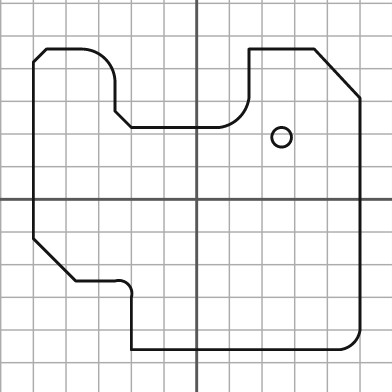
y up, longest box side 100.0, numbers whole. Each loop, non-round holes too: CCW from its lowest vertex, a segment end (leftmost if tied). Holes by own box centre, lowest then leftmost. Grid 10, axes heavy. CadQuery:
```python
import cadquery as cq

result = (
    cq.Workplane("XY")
    .moveTo(-20.0, -46.0)
    .lineTo(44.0, -46.0)
    .threePointArc((48.0, -44.0), (50.0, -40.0))
    .lineTo(50.0, 31.0)
    .lineTo(36.0, 46.0)
    .lineTo(16.0, 46.0)
    .lineTo(16.0, 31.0)
    .threePointArc((13.0, 25.0), (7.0, 22.0))
    .lineTo(-20.0, 22.0)
    .lineTo(-25.0, 27.0)
    .lineTo(-25.0, 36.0)
    .threePointArc((-28.0, 43.0), (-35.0, 46.0))
    .lineTo(-46.0, 46.0)
    .lineTo(-50.0, 42.0)
    .lineTo(-50.0, -12.0)
    .lineTo(-37.0, -25.0)
    .lineTo(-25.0, -25.0)
    .threePointArc((-21.0, -26.0), (-20.0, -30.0))
    .close()
    .moveTo(26.0, 19.0)
    .circle(3.0)
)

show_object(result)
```